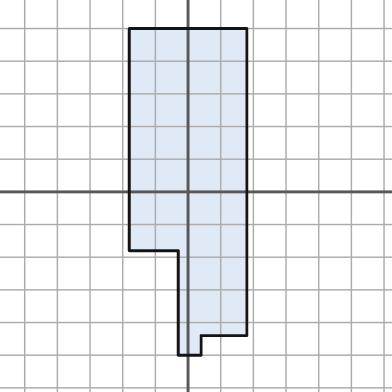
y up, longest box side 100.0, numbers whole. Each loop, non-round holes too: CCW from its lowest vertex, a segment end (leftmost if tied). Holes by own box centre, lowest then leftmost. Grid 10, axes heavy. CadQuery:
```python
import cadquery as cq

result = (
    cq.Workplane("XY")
    .moveTo(-3.0, -50.0)
    .lineTo(4.0, -50.0)
    .lineTo(4.0, -44.0)
    .lineTo(18.0, -44.0)
    .lineTo(18.0, 50.0)
    .lineTo(-18.0, 50.0)
    .lineTo(-18.0, -18.0)
    .lineTo(-3.0, -18.0)
    .close()
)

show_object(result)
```